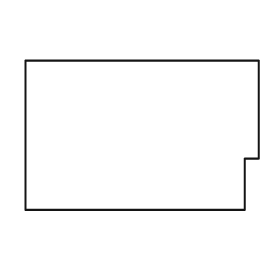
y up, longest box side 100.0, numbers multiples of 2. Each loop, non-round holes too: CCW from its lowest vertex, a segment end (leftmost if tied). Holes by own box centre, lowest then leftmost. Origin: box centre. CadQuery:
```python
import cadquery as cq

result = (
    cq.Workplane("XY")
    .moveTo(-50.0, -32.0)
    .lineTo(44.0, -32.0)
    .lineTo(44.0, -10.0)
    .lineTo(50.0, -10.0)
    .lineTo(50.0, 32.0)
    .lineTo(-50.0, 32.0)
    .close()
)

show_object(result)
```